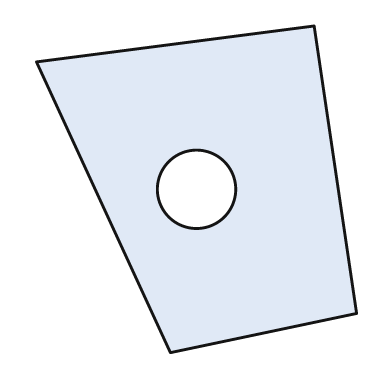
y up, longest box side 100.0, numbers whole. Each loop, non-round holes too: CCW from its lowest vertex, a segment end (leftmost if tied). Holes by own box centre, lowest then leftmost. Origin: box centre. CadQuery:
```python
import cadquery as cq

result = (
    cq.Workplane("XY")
    .moveTo(-8.0, -50.0)
    .lineTo(49.0, -38.0)
    .lineTo(36.0, 50.0)
    .lineTo(-49.0, 39.0)
    .close()
    .moveTo(0.0, 0.0)
    .circle(12.0)
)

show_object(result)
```